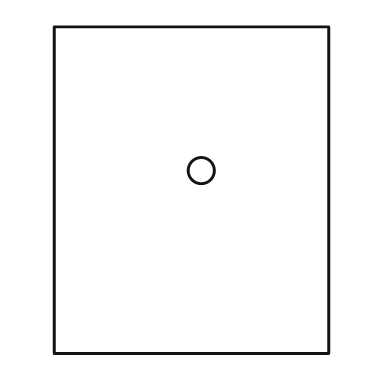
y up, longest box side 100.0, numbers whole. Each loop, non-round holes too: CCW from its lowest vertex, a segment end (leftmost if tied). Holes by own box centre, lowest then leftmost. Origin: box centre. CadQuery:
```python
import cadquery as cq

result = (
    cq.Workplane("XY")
    .moveTo(-42.0, -50.0)
    .lineTo(42.0, -50.0)
    .lineTo(42.0, 50.0)
    .lineTo(-42.0, 50.0)
    .close()
    .moveTo(3.0, 6.0)
    .circle(4.0)
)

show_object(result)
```